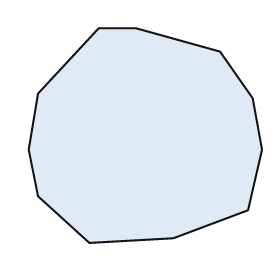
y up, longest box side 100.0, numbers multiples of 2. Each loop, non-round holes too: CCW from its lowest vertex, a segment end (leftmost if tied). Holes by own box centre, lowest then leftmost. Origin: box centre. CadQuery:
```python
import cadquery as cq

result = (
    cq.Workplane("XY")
    .moveTo(-24.0, -46.0)
    .lineTo(12.0, -44.0)
    .lineTo(44.0, -32.0)
    .lineTo(50.0, -6.0)
    .lineTo(46.0, 16.0)
    .lineTo(32.0, 36.0)
    .lineTo(-4.0, 46.0)
    .lineTo(-20.0, 46.0)
    .lineTo(-46.0, 18.0)
    .lineTo(-50.0, -6.0)
    .lineTo(-46.0, -26.0)
    .close()
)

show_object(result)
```